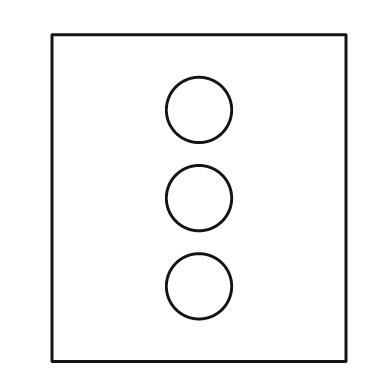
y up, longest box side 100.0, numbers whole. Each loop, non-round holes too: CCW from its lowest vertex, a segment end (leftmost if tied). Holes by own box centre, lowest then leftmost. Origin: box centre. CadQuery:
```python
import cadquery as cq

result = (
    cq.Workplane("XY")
    .moveTo(-45.0, -50.0)
    .lineTo(45.0, -50.0)
    .lineTo(45.0, 50.0)
    .lineTo(-45.0, 50.0)
    .close()
    .moveTo(0.0, -27.0)
    .circle(10.0)
    .moveTo(0.0, 0.0)
    .circle(10.0)
    .moveTo(0.0, 27.0)
    .circle(10.0)
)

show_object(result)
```